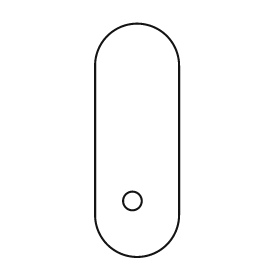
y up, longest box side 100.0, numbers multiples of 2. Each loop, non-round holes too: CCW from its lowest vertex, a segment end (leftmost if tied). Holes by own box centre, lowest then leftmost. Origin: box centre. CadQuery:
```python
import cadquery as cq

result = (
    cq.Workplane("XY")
    .moveTo(-18.0, -32.0)
    .threePointArc((0.0, -50.0), (18.0, -32.0))
    .lineTo(18.0, 32.0)
    .threePointArc((0.0, 50.0), (-18.0, 32.0))
    .close()
    .moveTo(-2.0, -26.0)
    .circle(4.0)
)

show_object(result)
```